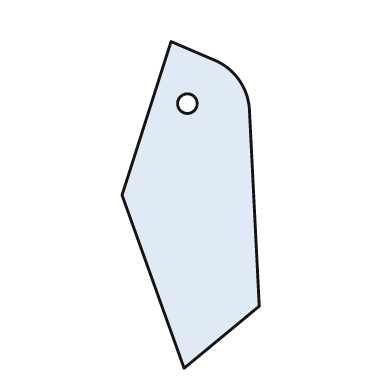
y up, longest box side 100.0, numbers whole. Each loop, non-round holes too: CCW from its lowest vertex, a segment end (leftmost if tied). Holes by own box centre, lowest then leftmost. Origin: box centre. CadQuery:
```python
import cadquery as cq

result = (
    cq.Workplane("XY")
    .moveTo(-2.0, -50.0)
    .lineTo(21.0, -31.0)
    .lineTo(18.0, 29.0)
    .threePointArc((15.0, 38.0), (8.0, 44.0))
    .lineTo(-6.0, 50.0)
    .lineTo(-21.0, 3.0)
    .close()
    .moveTo(-1.0, 31.0)
    .circle(3.0)
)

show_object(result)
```